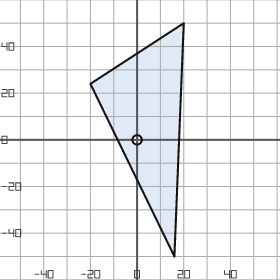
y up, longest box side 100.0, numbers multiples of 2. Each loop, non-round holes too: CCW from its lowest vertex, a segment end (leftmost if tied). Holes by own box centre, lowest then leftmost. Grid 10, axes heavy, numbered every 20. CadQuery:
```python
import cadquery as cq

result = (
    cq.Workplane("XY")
    .moveTo(16.0, -50.0)
    .lineTo(20.0, 50.0)
    .lineTo(-20.0, 24.0)
    .close()
    .moveTo(0.0, 0.0)
    .circle(2.0)
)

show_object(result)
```